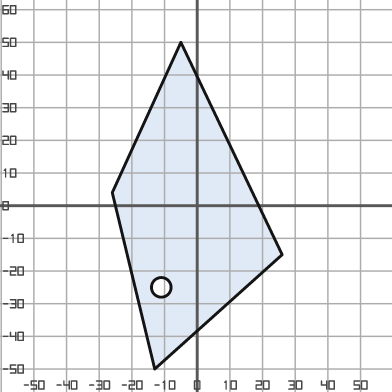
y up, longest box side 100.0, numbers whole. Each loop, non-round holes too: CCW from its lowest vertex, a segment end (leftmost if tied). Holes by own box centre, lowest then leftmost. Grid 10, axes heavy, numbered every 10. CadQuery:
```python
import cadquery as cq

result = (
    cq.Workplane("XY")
    .moveTo(-13.0, -50.0)
    .lineTo(26.0, -15.0)
    .lineTo(-5.0, 50.0)
    .lineTo(-26.0, 4.0)
    .close()
    .moveTo(-11.0, -25.0)
    .circle(3.0)
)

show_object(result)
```